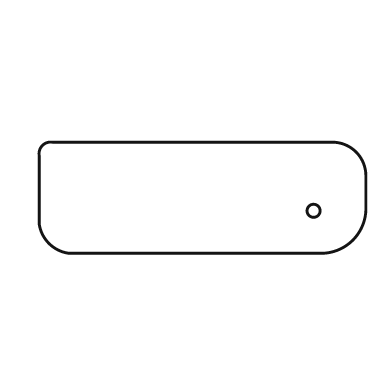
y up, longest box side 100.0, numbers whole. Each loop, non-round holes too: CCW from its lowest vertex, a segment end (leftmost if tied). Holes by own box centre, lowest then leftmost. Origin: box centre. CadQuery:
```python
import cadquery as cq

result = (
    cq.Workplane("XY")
    .moveTo(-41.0, -17.0)
    .lineTo(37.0, -17.0)
    .threePointArc((46.0, -13.0), (50.0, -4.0))
    .lineTo(50.0, 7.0)
    .threePointArc((47.0, 14.0), (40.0, 17.0))
    .lineTo(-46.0, 17.0)
    .threePointArc((-49.0, 16.0), (-50.0, 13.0))
    .lineTo(-50.0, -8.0)
    .threePointArc((-47.0, -14.0), (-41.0, -17.0))
    .close()
    .moveTo(34.0, -4.0)
    .circle(2.0)
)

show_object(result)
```